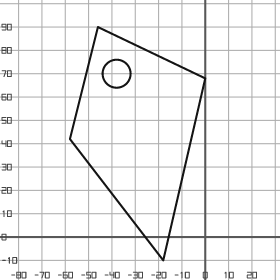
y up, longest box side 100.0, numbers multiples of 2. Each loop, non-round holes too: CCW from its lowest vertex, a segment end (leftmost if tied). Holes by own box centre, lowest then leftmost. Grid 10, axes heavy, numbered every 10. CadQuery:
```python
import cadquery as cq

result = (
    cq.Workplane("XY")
    .moveTo(-18.0, -10.0)
    .lineTo(0.0, 68.0)
    .lineTo(-46.0, 90.0)
    .lineTo(-58.0, 42.0)
    .close()
    .moveTo(-38.0, 70.0)
    .circle(6.0)
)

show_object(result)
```